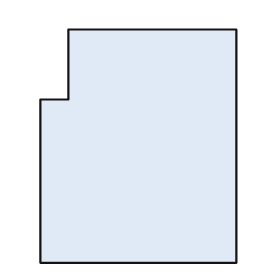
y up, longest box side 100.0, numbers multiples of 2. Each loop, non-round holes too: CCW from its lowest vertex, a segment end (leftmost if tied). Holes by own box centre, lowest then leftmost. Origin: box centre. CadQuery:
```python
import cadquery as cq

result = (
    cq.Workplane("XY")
    .moveTo(-42.0, -50.0)
    .lineTo(42.0, -50.0)
    .lineTo(42.0, 50.0)
    .lineTo(-30.0, 50.0)
    .lineTo(-30.0, 20.0)
    .lineTo(-42.0, 20.0)
    .close()
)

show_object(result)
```